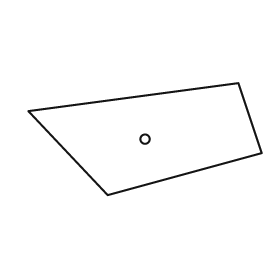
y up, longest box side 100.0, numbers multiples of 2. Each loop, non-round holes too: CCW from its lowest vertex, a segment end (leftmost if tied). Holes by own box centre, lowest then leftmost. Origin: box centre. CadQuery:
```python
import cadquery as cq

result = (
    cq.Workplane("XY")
    .moveTo(-16.0, -24.0)
    .lineTo(50.0, -6.0)
    .lineTo(40.0, 24.0)
    .lineTo(-50.0, 12.0)
    .close()
    .moveTo(0.0, 0.0)
    .circle(2.0)
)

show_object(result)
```